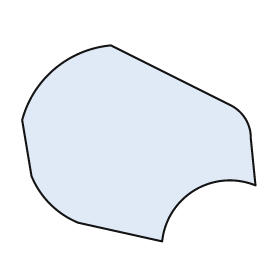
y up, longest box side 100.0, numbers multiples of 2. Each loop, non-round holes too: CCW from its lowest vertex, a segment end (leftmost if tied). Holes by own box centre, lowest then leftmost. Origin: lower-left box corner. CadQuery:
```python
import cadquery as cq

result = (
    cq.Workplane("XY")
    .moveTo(60.0, 0.0)
    .threePointArc((74.0, 22.0), (100.0, 24.0))
    .lineTo(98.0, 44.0)
    .threePointArc((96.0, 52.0), (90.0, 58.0))
    .lineTo(38.0, 84.0)
    .threePointArc((14.0, 74.0), (0.0, 52.0))
    .lineTo(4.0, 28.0)
    .threePointArc((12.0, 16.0), (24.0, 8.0))
    .close()
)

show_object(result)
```